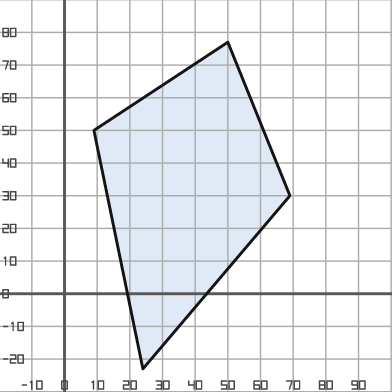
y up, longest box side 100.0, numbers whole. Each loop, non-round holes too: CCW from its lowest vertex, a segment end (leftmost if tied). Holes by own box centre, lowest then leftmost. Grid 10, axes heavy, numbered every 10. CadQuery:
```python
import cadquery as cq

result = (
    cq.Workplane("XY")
    .moveTo(24.0, -23.0)
    .lineTo(69.0, 30.0)
    .lineTo(50.0, 77.0)
    .lineTo(9.0, 50.0)
    .close()
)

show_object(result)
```